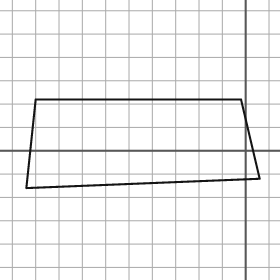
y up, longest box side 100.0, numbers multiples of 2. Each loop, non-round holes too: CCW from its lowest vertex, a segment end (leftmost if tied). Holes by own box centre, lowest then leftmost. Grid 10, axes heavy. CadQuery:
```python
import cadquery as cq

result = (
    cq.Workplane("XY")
    .moveTo(-94.0, -16.0)
    .lineTo(6.0, -12.0)
    .lineTo(-2.0, 22.0)
    .lineTo(-90.0, 22.0)
    .close()
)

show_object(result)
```